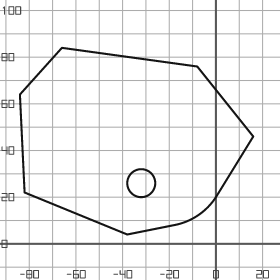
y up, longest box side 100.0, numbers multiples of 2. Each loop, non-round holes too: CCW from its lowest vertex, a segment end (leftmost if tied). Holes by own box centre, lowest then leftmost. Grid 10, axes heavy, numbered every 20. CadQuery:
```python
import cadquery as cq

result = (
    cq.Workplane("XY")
    .moveTo(-38.0, 4.0)
    .lineTo(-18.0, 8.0)
    .threePointArc((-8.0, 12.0), (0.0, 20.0))
    .lineTo(16.0, 46.0)
    .lineTo(-8.0, 76.0)
    .lineTo(-66.0, 84.0)
    .lineTo(-84.0, 64.0)
    .lineTo(-82.0, 22.0)
    .close()
    .moveTo(-32.0, 26.0)
    .circle(6.0)
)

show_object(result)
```